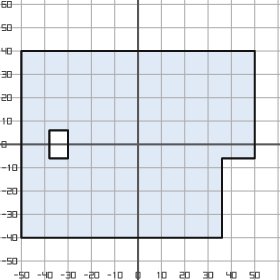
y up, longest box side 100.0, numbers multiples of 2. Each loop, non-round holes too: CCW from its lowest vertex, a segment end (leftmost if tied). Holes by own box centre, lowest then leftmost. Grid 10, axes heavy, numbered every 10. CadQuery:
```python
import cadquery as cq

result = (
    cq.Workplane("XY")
    .moveTo(-50.0, -40.0)
    .lineTo(36.0, -40.0)
    .lineTo(36.0, -6.0)
    .lineTo(50.0, -6.0)
    .lineTo(50.0, 40.0)
    .lineTo(-50.0, 40.0)
    .close()
    .moveTo(-38.0, -6.0)
    .lineTo(-30.0, -6.0)
    .lineTo(-30.0, 6.0)
    .lineTo(-38.0, 6.0)
    .close()
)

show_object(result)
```